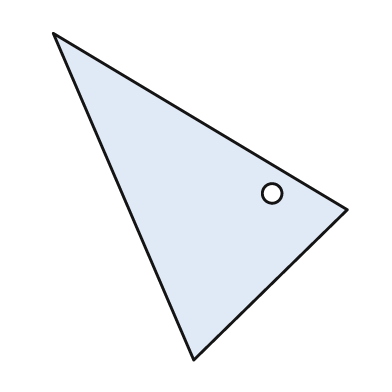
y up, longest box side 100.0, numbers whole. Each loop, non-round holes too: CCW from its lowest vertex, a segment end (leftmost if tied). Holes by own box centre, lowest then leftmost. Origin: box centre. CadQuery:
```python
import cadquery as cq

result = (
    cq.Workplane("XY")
    .moveTo(-2.0, -50.0)
    .lineTo(45.0, -4.0)
    .lineTo(-45.0, 50.0)
    .close()
    .moveTo(22.0, 1.0)
    .circle(3.0)
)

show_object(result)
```